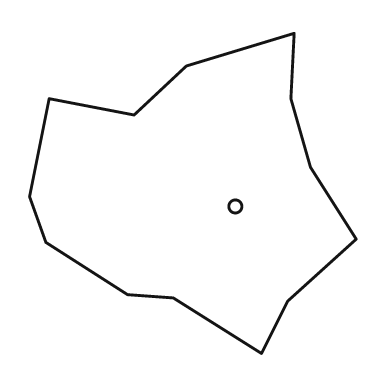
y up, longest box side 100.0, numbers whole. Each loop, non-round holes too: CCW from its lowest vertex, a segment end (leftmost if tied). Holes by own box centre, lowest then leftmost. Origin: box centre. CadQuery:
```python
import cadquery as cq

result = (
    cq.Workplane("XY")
    .moveTo(21.0, -49.0)
    .lineTo(29.0, -33.0)
    .lineTo(50.0, -14.0)
    .lineTo(36.0, 8.0)
    .lineTo(30.0, 29.0)
    .lineTo(31.0, 49.0)
    .lineTo(-2.0, 39.0)
    .lineTo(-18.0, 24.0)
    .lineTo(-44.0, 29.0)
    .lineTo(-50.0, -1.0)
    .lineTo(-45.0, -15.0)
    .lineTo(-20.0, -31.0)
    .lineTo(-6.0, -32.0)
    .close()
    .moveTo(13.0, -4.0)
    .circle(2.0)
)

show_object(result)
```